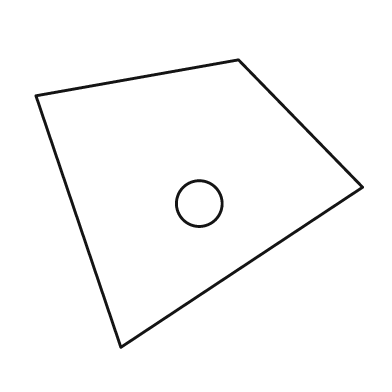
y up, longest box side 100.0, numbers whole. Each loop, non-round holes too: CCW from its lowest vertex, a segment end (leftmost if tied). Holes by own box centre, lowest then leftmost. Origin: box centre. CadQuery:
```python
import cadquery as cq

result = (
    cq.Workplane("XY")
    .moveTo(-24.0, -44.0)
    .lineTo(50.0, 5.0)
    .lineTo(12.0, 44.0)
    .lineTo(-50.0, 33.0)
    .close()
    .moveTo(0.0, 0.0)
    .circle(7.0)
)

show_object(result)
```